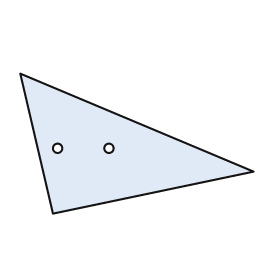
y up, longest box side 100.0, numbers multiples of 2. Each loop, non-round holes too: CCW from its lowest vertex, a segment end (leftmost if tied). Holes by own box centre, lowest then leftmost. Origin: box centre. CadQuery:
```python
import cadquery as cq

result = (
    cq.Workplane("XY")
    .moveTo(-36.0, -30.0)
    .lineTo(50.0, -12.0)
    .lineTo(-50.0, 30.0)
    .close()
    .moveTo(-34.0, -2.0)
    .circle(2.0)
    .moveTo(-12.0, -2.0)
    .circle(2.0)
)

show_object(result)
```